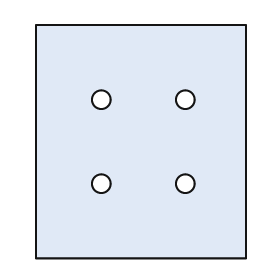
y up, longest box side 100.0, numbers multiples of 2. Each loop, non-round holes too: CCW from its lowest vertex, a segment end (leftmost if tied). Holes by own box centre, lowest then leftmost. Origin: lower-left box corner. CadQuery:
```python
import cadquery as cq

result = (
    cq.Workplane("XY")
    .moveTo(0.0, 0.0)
    .lineTo(90.0, 0.0)
    .lineTo(90.0, 100.0)
    .lineTo(0.0, 100.0)
    .close()
    .moveTo(28.0, 32.0)
    .circle(4.0)
    .moveTo(64.0, 32.0)
    .circle(4.0)
    .moveTo(28.0, 68.0)
    .circle(4.0)
    .moveTo(64.0, 68.0)
    .circle(4.0)
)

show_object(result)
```